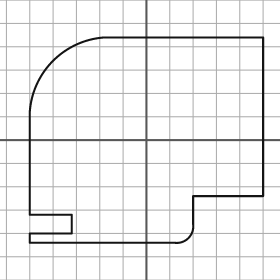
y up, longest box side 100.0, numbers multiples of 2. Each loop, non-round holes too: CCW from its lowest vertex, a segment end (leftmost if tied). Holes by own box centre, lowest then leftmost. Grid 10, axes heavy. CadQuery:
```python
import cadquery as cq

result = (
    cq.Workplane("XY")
    .moveTo(-50.0, -44.0)
    .lineTo(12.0, -44.0)
    .threePointArc((18.0, -42.0), (20.0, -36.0))
    .lineTo(20.0, -24.0)
    .lineTo(50.0, -24.0)
    .lineTo(50.0, 44.0)
    .lineTo(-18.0, 44.0)
    .threePointArc((-40.0, 34.0), (-50.0, 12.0))
    .lineTo(-50.0, -32.0)
    .lineTo(-32.0, -32.0)
    .lineTo(-32.0, -40.0)
    .lineTo(-50.0, -40.0)
    .close()
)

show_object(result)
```